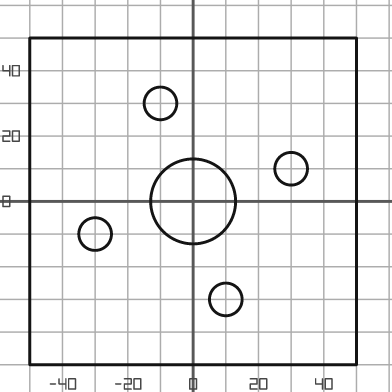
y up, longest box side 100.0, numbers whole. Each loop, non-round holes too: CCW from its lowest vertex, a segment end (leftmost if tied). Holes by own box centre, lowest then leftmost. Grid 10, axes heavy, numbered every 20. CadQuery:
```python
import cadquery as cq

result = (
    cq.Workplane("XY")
    .moveTo(-50.0, -50.0)
    .lineTo(50.0, -50.0)
    .lineTo(50.0, 50.0)
    .lineTo(-50.0, 50.0)
    .close()
    .moveTo(10.0, -30.0)
    .circle(5.0)
    .moveTo(-30.0, -10.0)
    .circle(5.0)
    .moveTo(0.0, 0.0)
    .circle(13.0)
    .moveTo(30.0, 10.0)
    .circle(5.0)
    .moveTo(-10.0, 30.0)
    .circle(5.0)
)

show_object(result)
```